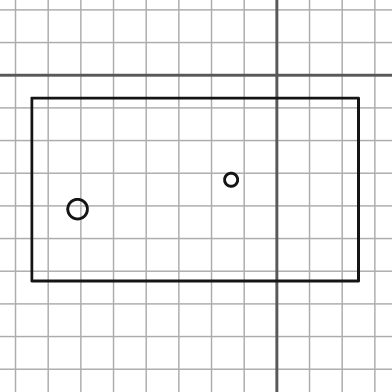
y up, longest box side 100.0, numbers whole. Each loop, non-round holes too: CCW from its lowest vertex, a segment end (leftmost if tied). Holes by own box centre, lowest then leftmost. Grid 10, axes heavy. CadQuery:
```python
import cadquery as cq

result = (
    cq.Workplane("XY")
    .moveTo(-75.0, -63.0)
    .lineTo(25.0, -63.0)
    .lineTo(25.0, -7.0)
    .lineTo(-75.0, -7.0)
    .close()
    .moveTo(-61.0, -41.0)
    .circle(3.0)
    .moveTo(-14.0, -32.0)
    .circle(2.0)
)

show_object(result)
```